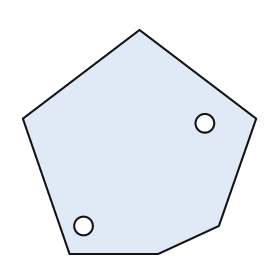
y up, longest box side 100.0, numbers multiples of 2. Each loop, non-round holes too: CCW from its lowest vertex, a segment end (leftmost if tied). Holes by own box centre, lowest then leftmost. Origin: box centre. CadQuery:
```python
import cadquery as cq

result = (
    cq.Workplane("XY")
    .moveTo(-30.0, -48.0)
    .lineTo(8.0, -48.0)
    .lineTo(34.0, -36.0)
    .lineTo(50.0, 10.0)
    .lineTo(0.0, 48.0)
    .lineTo(-50.0, 10.0)
    .close()
    .moveTo(-24.0, -36.0)
    .circle(4.0)
    .moveTo(28.0, 8.0)
    .circle(4.0)
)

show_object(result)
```